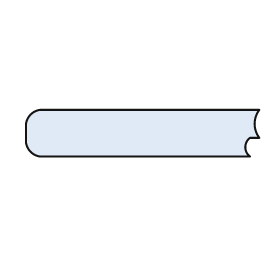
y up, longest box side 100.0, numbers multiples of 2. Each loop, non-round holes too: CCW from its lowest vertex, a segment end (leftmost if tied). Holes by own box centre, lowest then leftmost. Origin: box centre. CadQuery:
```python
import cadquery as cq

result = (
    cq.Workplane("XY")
    .moveTo(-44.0, -10.0)
    .lineTo(46.0, -10.0)
    .threePointArc((44.0, -6.0), (46.0, -2.0))
    .lineTo(50.0, -2.0)
    .threePointArc((48.0, 4.0), (50.0, 10.0))
    .lineTo(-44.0, 10.0)
    .threePointArc((-48.0, 8.0), (-50.0, 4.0))
    .lineTo(-50.0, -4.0)
    .threePointArc((-48.0, -8.0), (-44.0, -10.0))
    .close()
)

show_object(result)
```